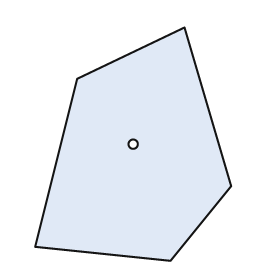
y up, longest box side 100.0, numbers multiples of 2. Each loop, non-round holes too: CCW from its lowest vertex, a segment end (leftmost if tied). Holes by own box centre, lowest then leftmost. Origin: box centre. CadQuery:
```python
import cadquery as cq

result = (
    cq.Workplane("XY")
    .moveTo(16.0, -50.0)
    .lineTo(42.0, -18.0)
    .lineTo(22.0, 50.0)
    .lineTo(-24.0, 28.0)
    .lineTo(-42.0, -44.0)
    .close()
    .moveTo(0.0, 0.0)
    .circle(2.0)
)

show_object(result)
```